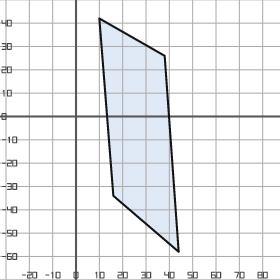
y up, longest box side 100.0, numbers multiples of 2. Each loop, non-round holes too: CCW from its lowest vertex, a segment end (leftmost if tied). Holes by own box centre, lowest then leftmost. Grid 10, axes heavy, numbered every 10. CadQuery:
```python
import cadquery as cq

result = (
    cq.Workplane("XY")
    .moveTo(44.0, -58.0)
    .lineTo(38.0, 26.0)
    .lineTo(10.0, 42.0)
    .lineTo(16.0, -34.0)
    .close()
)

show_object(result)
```